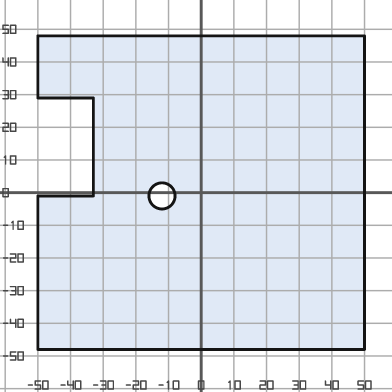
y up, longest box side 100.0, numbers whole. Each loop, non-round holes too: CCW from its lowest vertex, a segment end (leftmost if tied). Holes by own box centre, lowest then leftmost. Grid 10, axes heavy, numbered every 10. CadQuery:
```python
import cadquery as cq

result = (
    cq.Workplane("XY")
    .moveTo(-50.0, -48.0)
    .lineTo(50.0, -48.0)
    .lineTo(50.0, 48.0)
    .lineTo(-50.0, 48.0)
    .lineTo(-50.0, 29.0)
    .lineTo(-33.0, 29.0)
    .lineTo(-33.0, -1.0)
    .lineTo(-50.0, -1.0)
    .close()
    .moveTo(-12.0, -1.0)
    .circle(4.0)
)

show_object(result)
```